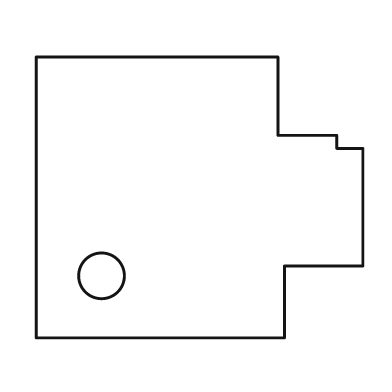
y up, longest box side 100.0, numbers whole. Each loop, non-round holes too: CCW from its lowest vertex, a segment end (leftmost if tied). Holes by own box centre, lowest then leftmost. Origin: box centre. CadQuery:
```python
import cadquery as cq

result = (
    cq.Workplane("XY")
    .moveTo(-50.0, -43.0)
    .lineTo(26.0, -43.0)
    .lineTo(26.0, -21.0)
    .lineTo(50.0, -21.0)
    .lineTo(50.0, 15.0)
    .lineTo(42.0, 15.0)
    .lineTo(42.0, 19.0)
    .lineTo(24.0, 19.0)
    .lineTo(24.0, 43.0)
    .lineTo(-50.0, 43.0)
    .close()
    .moveTo(-30.0, -24.0)
    .circle(7.0)
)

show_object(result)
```